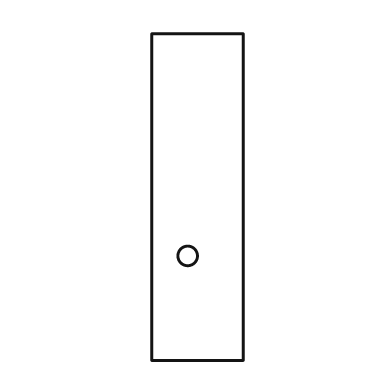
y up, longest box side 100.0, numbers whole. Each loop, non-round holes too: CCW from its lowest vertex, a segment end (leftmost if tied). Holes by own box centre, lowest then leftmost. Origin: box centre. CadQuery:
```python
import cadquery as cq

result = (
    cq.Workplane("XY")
    .moveTo(-14.0, -50.0)
    .lineTo(14.0, -50.0)
    .lineTo(14.0, 50.0)
    .lineTo(-14.0, 50.0)
    .close()
    .moveTo(-3.0, -18.0)
    .circle(3.0)
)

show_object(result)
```